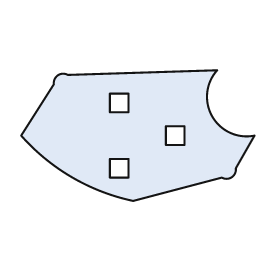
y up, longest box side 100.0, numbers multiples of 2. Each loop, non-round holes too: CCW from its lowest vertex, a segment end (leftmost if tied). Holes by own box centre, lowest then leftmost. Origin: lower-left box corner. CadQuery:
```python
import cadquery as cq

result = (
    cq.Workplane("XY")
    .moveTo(48.0, 0.0)
    .lineTo(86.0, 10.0)
    .threePointArc((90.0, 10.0), (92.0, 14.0))
    .lineTo(100.0, 28.0)
    .threePointArc((82.0, 36.0), (84.0, 56.0))
    .lineTo(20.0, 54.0)
    .threePointArc((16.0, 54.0), (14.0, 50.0))
    .lineTo(0.0, 28.0)
    .threePointArc((22.0, 10.0), (48.0, 0.0))
    .close()
    .moveTo(38.0, 10.0)
    .lineTo(46.0, 10.0)
    .lineTo(46.0, 18.0)
    .lineTo(38.0, 18.0)
    .close()
    .moveTo(62.0, 24.0)
    .lineTo(70.0, 24.0)
    .lineTo(70.0, 32.0)
    .lineTo(62.0, 32.0)
    .close()
    .moveTo(38.0, 38.0)
    .lineTo(46.0, 38.0)
    .lineTo(46.0, 46.0)
    .lineTo(38.0, 46.0)
    .close()
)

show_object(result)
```